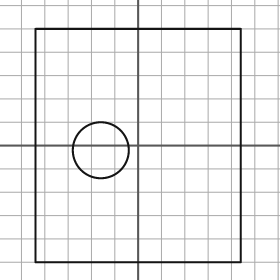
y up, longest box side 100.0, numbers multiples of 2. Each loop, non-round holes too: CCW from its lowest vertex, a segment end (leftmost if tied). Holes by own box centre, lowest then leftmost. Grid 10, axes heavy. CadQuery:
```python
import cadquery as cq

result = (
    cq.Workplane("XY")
    .moveTo(-44.0, -50.0)
    .lineTo(44.0, -50.0)
    .lineTo(44.0, 50.0)
    .lineTo(-44.0, 50.0)
    .close()
    .moveTo(-16.0, -2.0)
    .circle(12.0)
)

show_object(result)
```